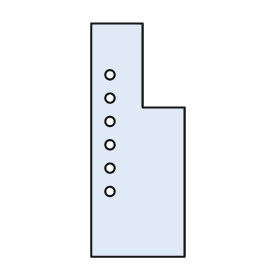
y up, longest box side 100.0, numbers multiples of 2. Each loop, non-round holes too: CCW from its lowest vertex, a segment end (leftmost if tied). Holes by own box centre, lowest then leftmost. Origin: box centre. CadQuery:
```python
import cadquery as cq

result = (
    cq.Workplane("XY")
    .moveTo(-20.0, -50.0)
    .lineTo(20.0, -50.0)
    .lineTo(20.0, 14.0)
    .lineTo(2.0, 14.0)
    .lineTo(2.0, 50.0)
    .lineTo(-20.0, 50.0)
    .close()
    .moveTo(-12.0, -22.0)
    .circle(2.0)
    .moveTo(-12.0, -12.0)
    .circle(2.0)
    .moveTo(-12.0, -2.0)
    .circle(2.0)
    .moveTo(-12.0, 8.0)
    .circle(2.0)
    .moveTo(-12.0, 18.0)
    .circle(2.0)
    .moveTo(-12.0, 28.0)
    .circle(2.0)
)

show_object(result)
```